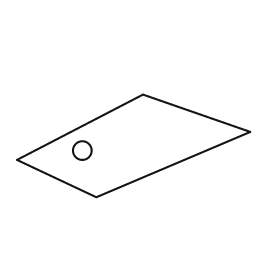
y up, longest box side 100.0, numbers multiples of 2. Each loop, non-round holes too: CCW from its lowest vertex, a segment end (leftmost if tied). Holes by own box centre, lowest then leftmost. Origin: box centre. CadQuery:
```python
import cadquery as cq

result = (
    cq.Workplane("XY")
    .moveTo(-16.0, -22.0)
    .lineTo(50.0, 6.0)
    .lineTo(4.0, 22.0)
    .lineTo(-50.0, -6.0)
    .close()
    .moveTo(-22.0, -2.0)
    .circle(4.0)
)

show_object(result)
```